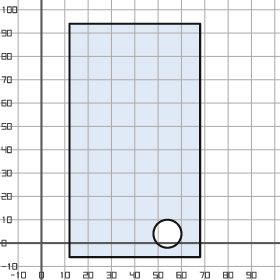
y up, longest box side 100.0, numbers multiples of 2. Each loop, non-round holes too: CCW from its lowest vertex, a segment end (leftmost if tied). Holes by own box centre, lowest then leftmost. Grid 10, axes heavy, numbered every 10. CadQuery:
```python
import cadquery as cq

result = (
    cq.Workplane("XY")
    .moveTo(12.0, -6.0)
    .lineTo(68.0, -6.0)
    .lineTo(68.0, 94.0)
    .lineTo(12.0, 94.0)
    .close()
    .moveTo(54.0, 4.0)
    .circle(6.0)
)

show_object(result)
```